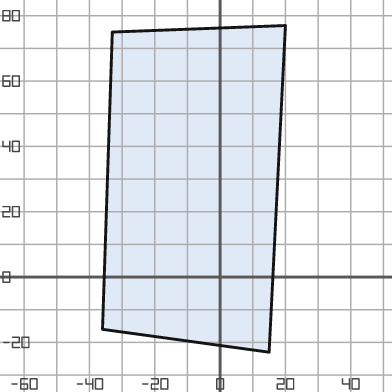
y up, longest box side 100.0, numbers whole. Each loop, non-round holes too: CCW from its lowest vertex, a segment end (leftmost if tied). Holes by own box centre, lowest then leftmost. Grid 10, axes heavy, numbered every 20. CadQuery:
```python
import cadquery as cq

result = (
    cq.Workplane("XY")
    .moveTo(15.0, -23.0)
    .lineTo(20.0, 77.0)
    .lineTo(-33.0, 75.0)
    .lineTo(-36.0, -16.0)
    .close()
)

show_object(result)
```